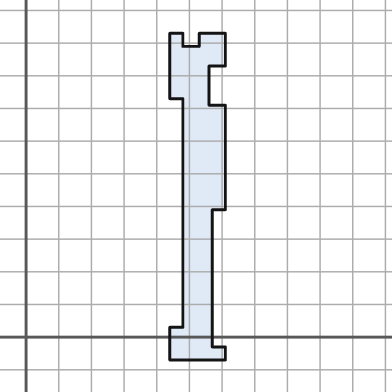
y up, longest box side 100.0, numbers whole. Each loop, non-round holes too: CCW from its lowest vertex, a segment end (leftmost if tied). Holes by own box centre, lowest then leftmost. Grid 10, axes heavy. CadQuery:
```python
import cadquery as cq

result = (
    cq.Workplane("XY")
    .moveTo(44.0, -7.0)
    .lineTo(61.0, -7.0)
    .lineTo(61.0, -3.0)
    .lineTo(57.0, -3.0)
    .lineTo(57.0, 39.0)
    .lineTo(61.0, 39.0)
    .lineTo(61.0, 71.0)
    .lineTo(56.0, 71.0)
    .lineTo(56.0, 83.0)
    .lineTo(61.0, 83.0)
    .lineTo(61.0, 93.0)
    .lineTo(53.0, 93.0)
    .lineTo(53.0, 89.0)
    .lineTo(48.0, 89.0)
    .lineTo(48.0, 93.0)
    .lineTo(44.0, 93.0)
    .lineTo(44.0, 73.0)
    .lineTo(48.0, 73.0)
    .lineTo(48.0, 3.0)
    .lineTo(44.0, 3.0)
    .close()
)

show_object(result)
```